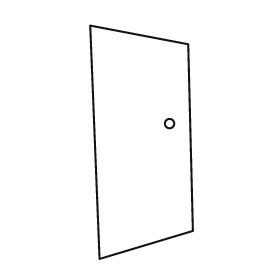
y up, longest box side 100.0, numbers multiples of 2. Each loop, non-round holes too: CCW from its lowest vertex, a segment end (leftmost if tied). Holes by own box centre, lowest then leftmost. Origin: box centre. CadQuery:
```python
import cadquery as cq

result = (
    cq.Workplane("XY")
    .moveTo(-18.0, -50.0)
    .lineTo(22.0, -38.0)
    .lineTo(20.0, 42.0)
    .lineTo(-22.0, 50.0)
    .close()
    .moveTo(12.0, 8.0)
    .circle(2.0)
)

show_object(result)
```